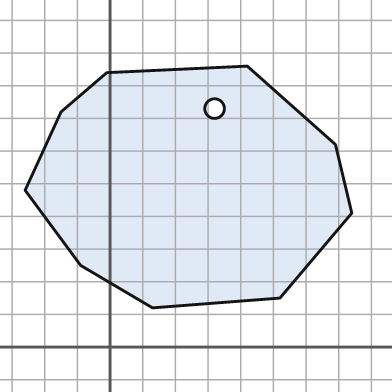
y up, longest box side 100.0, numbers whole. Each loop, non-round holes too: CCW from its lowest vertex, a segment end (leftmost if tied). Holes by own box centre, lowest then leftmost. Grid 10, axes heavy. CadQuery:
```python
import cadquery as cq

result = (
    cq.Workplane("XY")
    .moveTo(13.0, 12.0)
    .lineTo(52.0, 15.0)
    .lineTo(74.0, 41.0)
    .lineTo(69.0, 62.0)
    .lineTo(42.0, 86.0)
    .lineTo(-1.0, 84.0)
    .lineTo(-15.0, 72.0)
    .lineTo(-26.0, 48.0)
    .lineTo(-9.0, 25.0)
    .close()
    .moveTo(32.0, 73.0)
    .circle(3.0)
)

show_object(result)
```